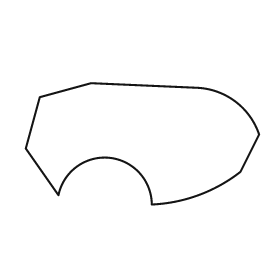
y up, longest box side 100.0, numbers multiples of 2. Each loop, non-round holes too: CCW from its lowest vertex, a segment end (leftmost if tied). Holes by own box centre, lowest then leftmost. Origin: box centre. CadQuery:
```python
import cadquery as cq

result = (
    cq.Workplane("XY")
    .moveTo(4.0, -26.0)
    .threePointArc((24.0, -22.0), (42.0, -12.0))
    .lineTo(50.0, 4.0)
    .threePointArc((40.0, 18.0), (24.0, 24.0))
    .lineTo(-22.0, 26.0)
    .lineTo(-44.0, 20.0)
    .lineTo(-50.0, -2.0)
    .lineTo(-36.0, -22.0)
    .threePointArc((-14.0, -6.0), (4.0, -26.0))
    .close()
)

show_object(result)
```